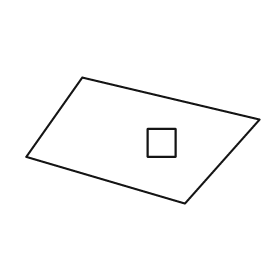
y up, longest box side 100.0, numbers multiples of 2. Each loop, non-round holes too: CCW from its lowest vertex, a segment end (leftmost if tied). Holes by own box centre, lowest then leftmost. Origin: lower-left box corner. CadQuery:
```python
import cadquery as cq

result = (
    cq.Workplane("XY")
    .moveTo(68.0, 0.0)
    .lineTo(100.0, 36.0)
    .lineTo(24.0, 54.0)
    .lineTo(0.0, 20.0)
    .close()
    .moveTo(52.0, 20.0)
    .lineTo(64.0, 20.0)
    .lineTo(64.0, 32.0)
    .lineTo(52.0, 32.0)
    .close()
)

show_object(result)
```